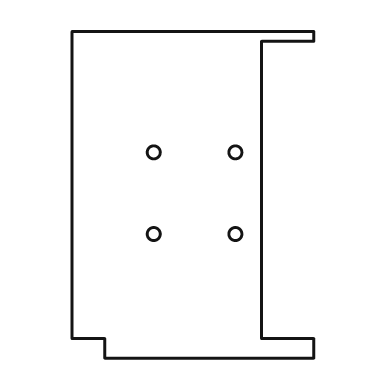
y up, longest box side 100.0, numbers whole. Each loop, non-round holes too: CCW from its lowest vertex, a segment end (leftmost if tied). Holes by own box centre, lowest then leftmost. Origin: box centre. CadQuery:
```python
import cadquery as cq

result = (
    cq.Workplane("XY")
    .moveTo(-27.0, -50.0)
    .lineTo(37.0, -50.0)
    .lineTo(37.0, -44.0)
    .lineTo(21.0, -44.0)
    .lineTo(21.0, 47.0)
    .lineTo(37.0, 47.0)
    .lineTo(37.0, 50.0)
    .lineTo(-37.0, 50.0)
    .lineTo(-37.0, -44.0)
    .lineTo(-27.0, -44.0)
    .close()
    .moveTo(-12.0, -12.0)
    .circle(2.0)
    .moveTo(13.0, -12.0)
    .circle(2.0)
    .moveTo(-12.0, 13.0)
    .circle(2.0)
    .moveTo(13.0, 13.0)
    .circle(2.0)
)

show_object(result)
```